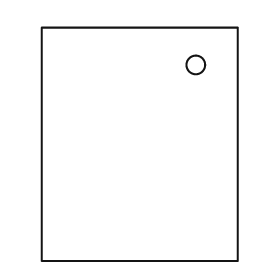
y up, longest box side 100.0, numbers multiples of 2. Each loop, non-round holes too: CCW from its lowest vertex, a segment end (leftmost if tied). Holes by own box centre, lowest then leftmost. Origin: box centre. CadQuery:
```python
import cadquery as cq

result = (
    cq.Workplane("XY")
    .moveTo(-42.0, -50.0)
    .lineTo(42.0, -50.0)
    .lineTo(42.0, 50.0)
    .lineTo(-42.0, 50.0)
    .close()
    .moveTo(24.0, 34.0)
    .circle(4.0)
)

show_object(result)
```